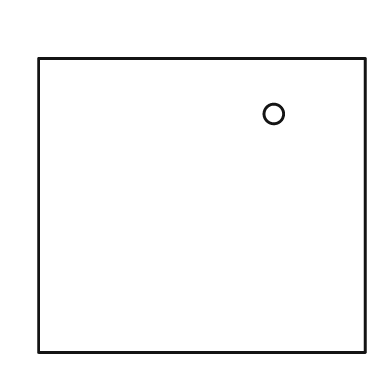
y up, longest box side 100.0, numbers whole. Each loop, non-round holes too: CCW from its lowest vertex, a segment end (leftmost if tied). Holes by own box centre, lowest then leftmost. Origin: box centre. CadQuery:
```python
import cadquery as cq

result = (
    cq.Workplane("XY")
    .moveTo(-50.0, -45.0)
    .lineTo(50.0, -45.0)
    .lineTo(50.0, 45.0)
    .lineTo(-50.0, 45.0)
    .close()
    .moveTo(22.0, 28.0)
    .circle(3.0)
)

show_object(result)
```